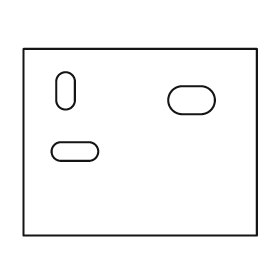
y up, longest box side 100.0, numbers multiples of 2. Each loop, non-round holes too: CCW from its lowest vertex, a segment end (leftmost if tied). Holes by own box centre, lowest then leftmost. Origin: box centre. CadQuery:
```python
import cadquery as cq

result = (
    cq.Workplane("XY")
    .moveTo(-50.0, -40.0)
    .lineTo(50.0, -40.0)
    .lineTo(50.0, 40.0)
    .lineTo(-50.0, 40.0)
    .close()
    .moveTo(-34.0, -8.0)
    .lineTo(-22.0, -8.0)
    .threePointArc((-18.0, -4.0), (-22.0, 0.0))
    .lineTo(-34.0, 0.0)
    .threePointArc((-38.0, -4.0), (-34.0, -8.0))
    .close()
    .moveTo(18.0, 12.0)
    .lineTo(26.0, 12.0)
    .threePointArc((32.0, 18.0), (26.0, 24.0))
    .lineTo(18.0, 24.0)
    .threePointArc((12.0, 18.0), (18.0, 12.0))
    .close()
    .moveTo(-36.0, 18.0)
    .threePointArc((-32.0, 14.0), (-28.0, 18.0))
    .lineTo(-28.0, 26.0)
    .threePointArc((-32.0, 30.0), (-36.0, 26.0))
    .close()
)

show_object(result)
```